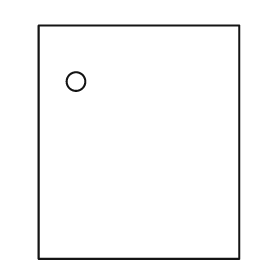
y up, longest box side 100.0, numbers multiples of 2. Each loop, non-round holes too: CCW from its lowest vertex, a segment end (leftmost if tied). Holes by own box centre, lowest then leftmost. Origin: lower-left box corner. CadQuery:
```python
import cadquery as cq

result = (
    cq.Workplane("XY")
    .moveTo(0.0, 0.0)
    .lineTo(86.0, 0.0)
    .lineTo(86.0, 100.0)
    .lineTo(0.0, 100.0)
    .close()
    .moveTo(16.0, 76.0)
    .circle(4.0)
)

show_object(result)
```